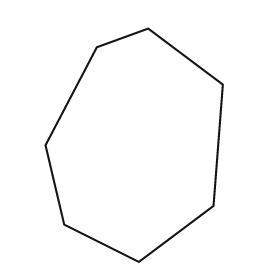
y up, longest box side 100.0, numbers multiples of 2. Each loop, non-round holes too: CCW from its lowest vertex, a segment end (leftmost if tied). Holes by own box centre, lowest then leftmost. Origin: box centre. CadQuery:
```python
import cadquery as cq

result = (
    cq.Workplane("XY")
    .moveTo(2.0, -50.0)
    .lineTo(34.0, -26.0)
    .lineTo(38.0, 26.0)
    .lineTo(6.0, 50.0)
    .lineTo(-16.0, 42.0)
    .lineTo(-38.0, 0.0)
    .lineTo(-30.0, -34.0)
    .close()
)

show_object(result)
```